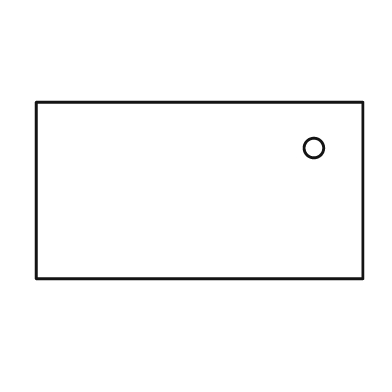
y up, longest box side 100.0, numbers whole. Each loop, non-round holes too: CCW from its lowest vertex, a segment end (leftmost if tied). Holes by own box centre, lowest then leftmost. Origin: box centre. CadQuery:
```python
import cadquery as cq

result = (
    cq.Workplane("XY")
    .moveTo(-50.0, -27.0)
    .lineTo(50.0, -27.0)
    .lineTo(50.0, 27.0)
    .lineTo(-50.0, 27.0)
    .close()
    .moveTo(35.0, 13.0)
    .circle(3.0)
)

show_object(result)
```